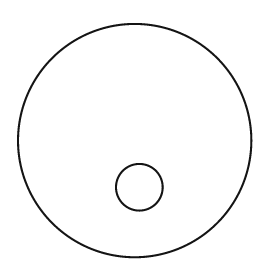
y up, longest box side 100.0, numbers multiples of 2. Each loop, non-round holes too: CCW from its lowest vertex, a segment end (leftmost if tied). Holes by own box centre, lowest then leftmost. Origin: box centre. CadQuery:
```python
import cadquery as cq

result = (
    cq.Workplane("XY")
    .moveTo(0.0, 0.0)
    .circle(50.0)
    .moveTo(2.0, -20.0)
    .circle(10.0)
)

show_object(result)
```